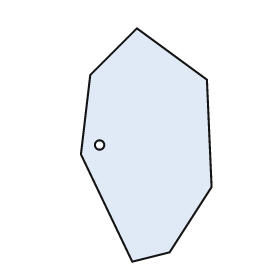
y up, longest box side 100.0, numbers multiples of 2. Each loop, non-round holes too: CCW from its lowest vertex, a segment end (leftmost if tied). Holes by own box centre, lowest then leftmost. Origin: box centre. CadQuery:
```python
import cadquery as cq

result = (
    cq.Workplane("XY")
    .moveTo(-6.0, -50.0)
    .lineTo(10.0, -46.0)
    .lineTo(28.0, -18.0)
    .lineTo(26.0, 28.0)
    .lineTo(-4.0, 50.0)
    .lineTo(-24.0, 30.0)
    .lineTo(-28.0, -4.0)
    .close()
    .moveTo(-20.0, 0.0)
    .circle(2.0)
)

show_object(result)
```